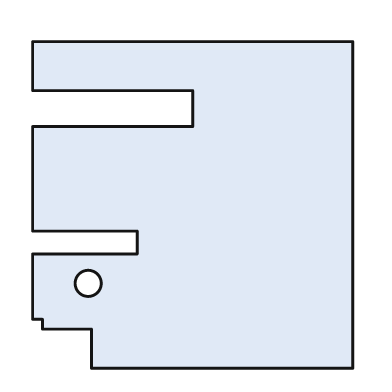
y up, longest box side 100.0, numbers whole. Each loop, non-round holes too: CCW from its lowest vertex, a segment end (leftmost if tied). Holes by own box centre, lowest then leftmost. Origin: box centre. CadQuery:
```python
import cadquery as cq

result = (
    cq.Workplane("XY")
    .moveTo(-31.0, -50.0)
    .lineTo(49.0, -50.0)
    .lineTo(49.0, 50.0)
    .lineTo(-49.0, 50.0)
    .lineTo(-49.0, 35.0)
    .lineTo(0.0, 35.0)
    .lineTo(0.0, 24.0)
    .lineTo(-49.0, 24.0)
    .lineTo(-49.0, -8.0)
    .lineTo(-17.0, -8.0)
    .lineTo(-17.0, -15.0)
    .lineTo(-49.0, -15.0)
    .lineTo(-49.0, -35.0)
    .lineTo(-46.0, -35.0)
    .lineTo(-46.0, -38.0)
    .lineTo(-31.0, -38.0)
    .close()
    .moveTo(-32.0, -24.0)
    .circle(4.0)
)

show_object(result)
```